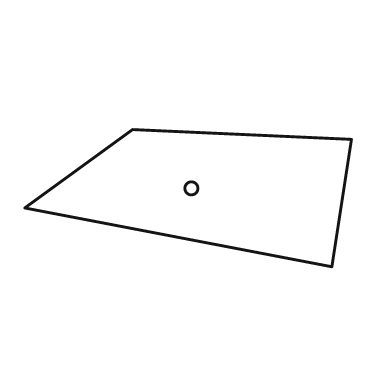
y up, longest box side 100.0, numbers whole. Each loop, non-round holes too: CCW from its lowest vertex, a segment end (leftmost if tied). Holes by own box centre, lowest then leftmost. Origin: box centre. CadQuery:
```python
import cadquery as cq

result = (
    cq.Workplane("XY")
    .moveTo(44.0, -21.0)
    .lineTo(50.0, 18.0)
    .lineTo(-17.0, 21.0)
    .lineTo(-50.0, -3.0)
    .close()
    .moveTo(1.0, 3.0)
    .circle(2.0)
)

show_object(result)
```